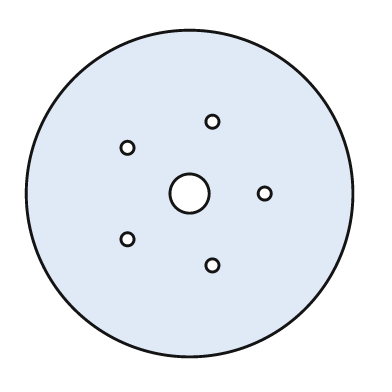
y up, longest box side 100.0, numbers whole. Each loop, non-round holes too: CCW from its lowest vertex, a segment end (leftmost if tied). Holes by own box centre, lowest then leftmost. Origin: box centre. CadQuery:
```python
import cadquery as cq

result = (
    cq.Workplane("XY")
    .moveTo(0.0, 0.0)
    .circle(50.0)
    .moveTo(7.0, -22.0)
    .circle(2.0)
    .moveTo(-19.0, -14.0)
    .circle(2.0)
    .moveTo(0.0, 0.0)
    .circle(6.0)
    .moveTo(23.0, 0.0)
    .circle(2.0)
    .moveTo(-19.0, 14.0)
    .circle(2.0)
    .moveTo(7.0, 22.0)
    .circle(2.0)
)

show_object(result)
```